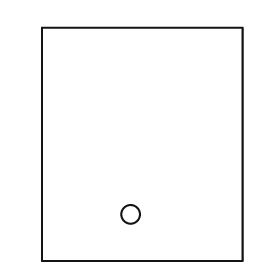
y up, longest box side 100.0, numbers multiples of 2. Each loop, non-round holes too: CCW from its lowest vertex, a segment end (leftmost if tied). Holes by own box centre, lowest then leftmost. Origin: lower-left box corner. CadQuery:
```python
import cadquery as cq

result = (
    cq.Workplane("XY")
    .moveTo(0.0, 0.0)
    .lineTo(86.0, 0.0)
    .lineTo(86.0, 100.0)
    .lineTo(0.0, 100.0)
    .close()
    .moveTo(38.0, 20.0)
    .circle(4.0)
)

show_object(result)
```